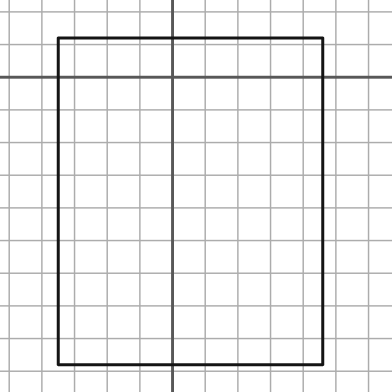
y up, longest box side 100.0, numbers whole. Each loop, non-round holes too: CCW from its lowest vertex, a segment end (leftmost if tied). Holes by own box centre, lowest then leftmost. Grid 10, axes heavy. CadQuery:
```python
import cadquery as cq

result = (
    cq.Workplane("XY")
    .moveTo(-35.0, -88.0)
    .lineTo(46.0, -88.0)
    .lineTo(46.0, 12.0)
    .lineTo(-35.0, 12.0)
    .close()
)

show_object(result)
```